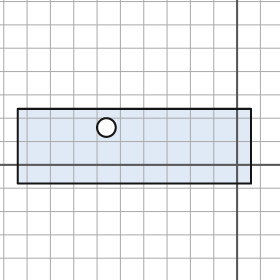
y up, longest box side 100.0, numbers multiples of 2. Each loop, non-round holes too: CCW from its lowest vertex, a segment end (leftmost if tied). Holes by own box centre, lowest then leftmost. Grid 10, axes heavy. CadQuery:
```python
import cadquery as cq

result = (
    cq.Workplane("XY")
    .moveTo(-94.0, -8.0)
    .lineTo(6.0, -8.0)
    .lineTo(6.0, 24.0)
    .lineTo(-94.0, 24.0)
    .close()
    .moveTo(-56.0, 16.0)
    .circle(4.0)
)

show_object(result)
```